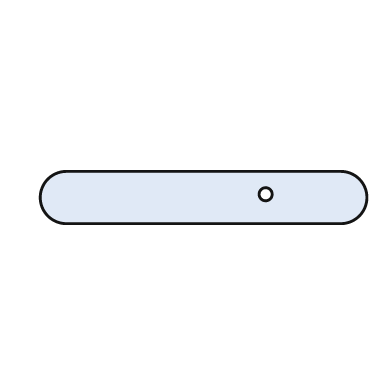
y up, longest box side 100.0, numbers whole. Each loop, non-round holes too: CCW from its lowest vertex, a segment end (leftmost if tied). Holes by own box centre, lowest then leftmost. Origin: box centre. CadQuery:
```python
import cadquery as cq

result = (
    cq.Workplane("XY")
    .moveTo(-42.0, -8.0)
    .lineTo(42.0, -8.0)
    .threePointArc((50.0, 0.0), (42.0, 8.0))
    .lineTo(-42.0, 8.0)
    .threePointArc((-50.0, 0.0), (-42.0, -8.0))
    .close()
    .moveTo(19.0, 1.0)
    .circle(2.0)
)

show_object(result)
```